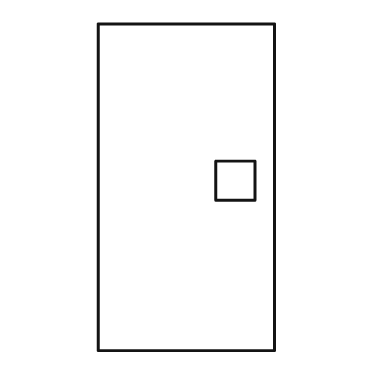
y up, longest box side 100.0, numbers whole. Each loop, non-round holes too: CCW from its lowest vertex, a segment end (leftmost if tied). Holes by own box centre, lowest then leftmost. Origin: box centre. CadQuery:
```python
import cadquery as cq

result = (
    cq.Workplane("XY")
    .moveTo(-27.0, -50.0)
    .lineTo(27.0, -50.0)
    .lineTo(27.0, 50.0)
    .lineTo(-27.0, 50.0)
    .close()
    .moveTo(9.0, -4.0)
    .lineTo(21.0, -4.0)
    .lineTo(21.0, 8.0)
    .lineTo(9.0, 8.0)
    .close()
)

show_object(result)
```